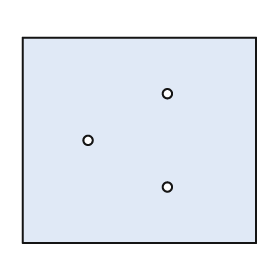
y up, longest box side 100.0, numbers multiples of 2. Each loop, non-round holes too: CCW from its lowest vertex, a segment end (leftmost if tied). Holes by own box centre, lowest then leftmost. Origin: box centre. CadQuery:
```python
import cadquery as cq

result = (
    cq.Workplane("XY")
    .moveTo(-50.0, -44.0)
    .lineTo(50.0, -44.0)
    .lineTo(50.0, 44.0)
    .lineTo(-50.0, 44.0)
    .close()
    .moveTo(12.0, -20.0)
    .circle(2.0)
    .moveTo(-22.0, 0.0)
    .circle(2.0)
    .moveTo(12.0, 20.0)
    .circle(2.0)
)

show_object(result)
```